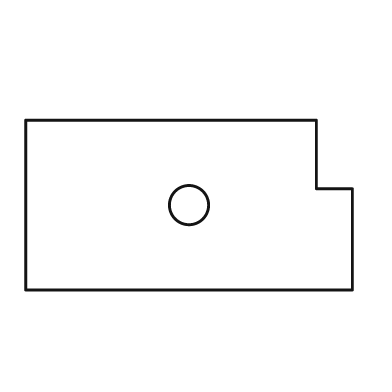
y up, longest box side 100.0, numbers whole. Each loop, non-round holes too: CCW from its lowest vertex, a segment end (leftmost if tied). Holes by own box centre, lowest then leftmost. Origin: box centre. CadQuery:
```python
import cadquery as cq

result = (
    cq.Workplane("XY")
    .moveTo(-50.0, -26.0)
    .lineTo(50.0, -26.0)
    .lineTo(50.0, 5.0)
    .lineTo(39.0, 5.0)
    .lineTo(39.0, 26.0)
    .lineTo(-50.0, 26.0)
    .close()
    .moveTo(0.0, 0.0)
    .circle(6.0)
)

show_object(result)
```